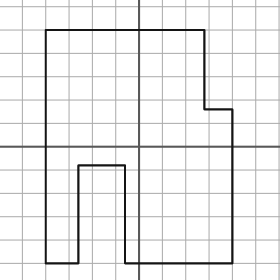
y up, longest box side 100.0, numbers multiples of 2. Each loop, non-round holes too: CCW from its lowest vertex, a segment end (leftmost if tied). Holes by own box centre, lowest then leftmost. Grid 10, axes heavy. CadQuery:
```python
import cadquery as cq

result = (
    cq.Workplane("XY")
    .moveTo(-40.0, -50.0)
    .lineTo(-26.0, -50.0)
    .lineTo(-26.0, -8.0)
    .lineTo(-6.0, -8.0)
    .lineTo(-6.0, -50.0)
    .lineTo(40.0, -50.0)
    .lineTo(40.0, 16.0)
    .lineTo(28.0, 16.0)
    .lineTo(28.0, 50.0)
    .lineTo(-40.0, 50.0)
    .close()
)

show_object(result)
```